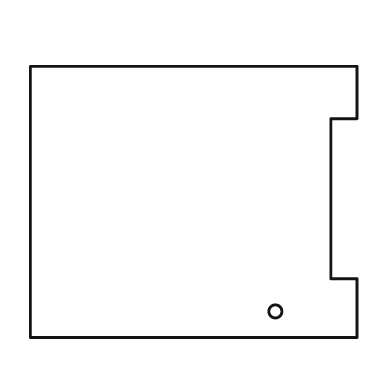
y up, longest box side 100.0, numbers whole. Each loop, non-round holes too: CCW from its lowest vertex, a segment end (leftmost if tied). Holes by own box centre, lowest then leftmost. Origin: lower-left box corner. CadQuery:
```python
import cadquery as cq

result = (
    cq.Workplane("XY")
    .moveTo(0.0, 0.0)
    .lineTo(100.0, 0.0)
    .lineTo(100.0, 18.0)
    .lineTo(92.0, 18.0)
    .lineTo(92.0, 67.0)
    .lineTo(100.0, 67.0)
    .lineTo(100.0, 83.0)
    .lineTo(0.0, 83.0)
    .close()
    .moveTo(75.0, 8.0)
    .circle(2.0)
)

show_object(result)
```